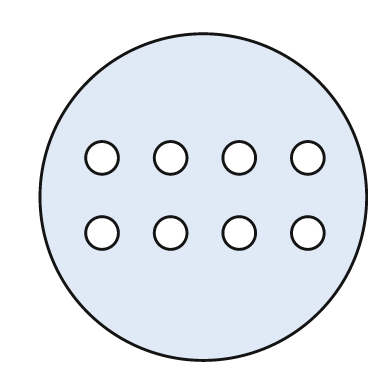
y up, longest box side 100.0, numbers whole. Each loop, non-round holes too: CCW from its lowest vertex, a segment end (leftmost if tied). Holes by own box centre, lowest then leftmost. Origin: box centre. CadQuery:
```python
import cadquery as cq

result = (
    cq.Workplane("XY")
    .moveTo(0.0, 0.0)
    .circle(50.0)
    .moveTo(-31.0, -11.0)
    .circle(5.0)
    .moveTo(-10.0, -11.0)
    .circle(5.0)
    .moveTo(11.0, -11.0)
    .circle(5.0)
    .moveTo(32.0, -11.0)
    .circle(5.0)
    .moveTo(-31.0, 12.0)
    .circle(5.0)
    .moveTo(-10.0, 12.0)
    .circle(5.0)
    .moveTo(11.0, 12.0)
    .circle(5.0)
    .moveTo(32.0, 12.0)
    .circle(5.0)
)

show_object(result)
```